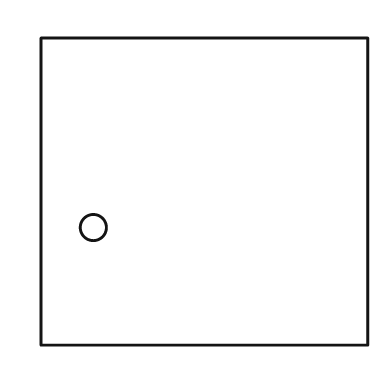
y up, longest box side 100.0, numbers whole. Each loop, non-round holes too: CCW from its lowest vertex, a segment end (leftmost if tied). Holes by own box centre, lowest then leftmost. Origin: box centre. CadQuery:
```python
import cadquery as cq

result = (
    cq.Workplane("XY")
    .moveTo(-50.0, -47.0)
    .lineTo(50.0, -47.0)
    .lineTo(50.0, 47.0)
    .lineTo(-50.0, 47.0)
    .close()
    .moveTo(-34.0, -11.0)
    .circle(4.0)
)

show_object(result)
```